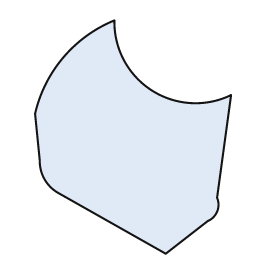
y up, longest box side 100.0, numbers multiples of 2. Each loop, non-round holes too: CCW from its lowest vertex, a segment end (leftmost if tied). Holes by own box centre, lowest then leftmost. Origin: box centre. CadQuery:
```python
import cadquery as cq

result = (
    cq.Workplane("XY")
    .moveTo(14.0, -50.0)
    .lineTo(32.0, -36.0)
    .threePointArc((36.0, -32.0), (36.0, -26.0))
    .lineTo(42.0, 18.0)
    .threePointArc((8.0, 20.0), (-8.0, 50.0))
    .threePointArc((-30.0, 34.0), (-42.0, 10.0))
    .lineTo(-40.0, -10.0)
    .threePointArc((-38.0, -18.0), (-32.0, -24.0))
    .close()
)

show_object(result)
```